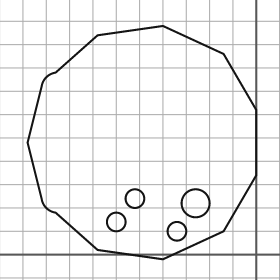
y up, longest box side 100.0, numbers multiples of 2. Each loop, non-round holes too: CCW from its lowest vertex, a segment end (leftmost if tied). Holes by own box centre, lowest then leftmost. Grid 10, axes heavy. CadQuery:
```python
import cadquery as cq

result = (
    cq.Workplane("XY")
    .moveTo(-40.0, -2.0)
    .lineTo(-14.0, 10.0)
    .lineTo(0.0, 34.0)
    .lineTo(0.0, 62.0)
    .lineTo(-14.0, 86.0)
    .lineTo(-40.0, 98.0)
    .lineTo(-68.0, 94.0)
    .lineTo(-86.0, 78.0)
    .threePointArc((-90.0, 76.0), (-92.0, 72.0))
    .lineTo(-98.0, 48.0)
    .lineTo(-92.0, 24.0)
    .threePointArc((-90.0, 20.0), (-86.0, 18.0))
    .lineTo(-68.0, 2.0)
    .close()
    .moveTo(-34.0, 10.0)
    .circle(4.0)
    .moveTo(-60.0, 14.0)
    .circle(4.0)
    .moveTo(-26.0, 22.0)
    .circle(6.0)
    .moveTo(-52.0, 24.0)
    .circle(4.0)
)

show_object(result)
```